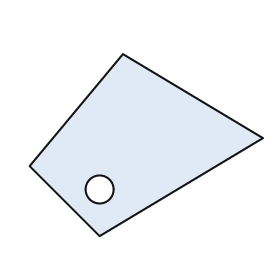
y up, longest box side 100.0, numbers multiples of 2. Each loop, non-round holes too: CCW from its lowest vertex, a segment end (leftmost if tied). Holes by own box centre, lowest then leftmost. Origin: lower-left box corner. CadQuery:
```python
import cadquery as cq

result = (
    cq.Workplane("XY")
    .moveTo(30.0, 0.0)
    .lineTo(100.0, 42.0)
    .lineTo(40.0, 78.0)
    .lineTo(0.0, 30.0)
    .close()
    .moveTo(30.0, 20.0)
    .circle(6.0)
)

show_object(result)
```